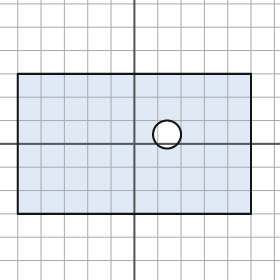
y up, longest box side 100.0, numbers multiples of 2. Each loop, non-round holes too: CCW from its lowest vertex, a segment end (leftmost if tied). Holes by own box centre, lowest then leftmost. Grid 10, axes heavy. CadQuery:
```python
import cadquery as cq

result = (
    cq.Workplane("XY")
    .moveTo(-50.0, -30.0)
    .lineTo(50.0, -30.0)
    .lineTo(50.0, 30.0)
    .lineTo(-50.0, 30.0)
    .close()
    .moveTo(14.0, 4.0)
    .circle(6.0)
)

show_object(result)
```